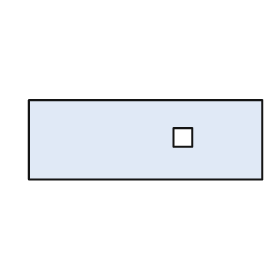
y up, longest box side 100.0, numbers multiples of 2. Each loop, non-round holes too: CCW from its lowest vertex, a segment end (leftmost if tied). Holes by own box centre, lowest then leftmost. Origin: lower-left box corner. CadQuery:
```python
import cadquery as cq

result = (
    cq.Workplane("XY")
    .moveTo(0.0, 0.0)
    .lineTo(100.0, 0.0)
    .lineTo(100.0, 34.0)
    .lineTo(0.0, 34.0)
    .close()
    .moveTo(62.0, 14.0)
    .lineTo(70.0, 14.0)
    .lineTo(70.0, 22.0)
    .lineTo(62.0, 22.0)
    .close()
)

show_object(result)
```